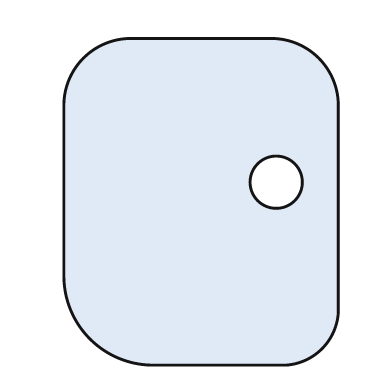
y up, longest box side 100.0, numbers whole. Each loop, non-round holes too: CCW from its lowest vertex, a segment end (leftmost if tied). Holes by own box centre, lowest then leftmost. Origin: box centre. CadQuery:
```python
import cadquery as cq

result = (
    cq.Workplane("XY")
    .moveTo(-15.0, -50.0)
    .lineTo(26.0, -50.0)
    .threePointArc((37.0, -45.0), (42.0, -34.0))
    .lineTo(42.0, 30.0)
    .threePointArc((36.0, 44.0), (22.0, 50.0))
    .lineTo(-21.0, 50.0)
    .threePointArc((-36.0, 44.0), (-42.0, 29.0))
    .lineTo(-42.0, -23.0)
    .threePointArc((-34.0, -42.0), (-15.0, -50.0))
    .close()
    .moveTo(23.0, 6.0)
    .circle(8.0)
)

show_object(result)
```